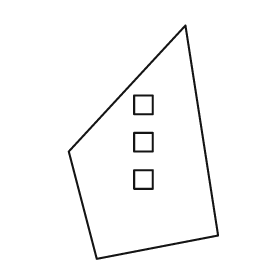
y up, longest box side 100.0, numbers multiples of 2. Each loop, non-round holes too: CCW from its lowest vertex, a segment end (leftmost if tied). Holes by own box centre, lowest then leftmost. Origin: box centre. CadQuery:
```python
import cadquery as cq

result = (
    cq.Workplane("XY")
    .moveTo(-20.0, -50.0)
    .lineTo(32.0, -40.0)
    .lineTo(18.0, 50.0)
    .lineTo(-32.0, -4.0)
    .close()
    .moveTo(-4.0, -20.0)
    .lineTo(4.0, -20.0)
    .lineTo(4.0, -12.0)
    .lineTo(-4.0, -12.0)
    .close()
    .moveTo(-4.0, -4.0)
    .lineTo(4.0, -4.0)
    .lineTo(4.0, 4.0)
    .lineTo(-4.0, 4.0)
    .close()
    .moveTo(-4.0, 12.0)
    .lineTo(4.0, 12.0)
    .lineTo(4.0, 20.0)
    .lineTo(-4.0, 20.0)
    .close()
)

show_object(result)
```